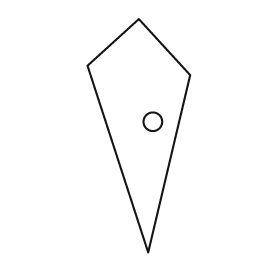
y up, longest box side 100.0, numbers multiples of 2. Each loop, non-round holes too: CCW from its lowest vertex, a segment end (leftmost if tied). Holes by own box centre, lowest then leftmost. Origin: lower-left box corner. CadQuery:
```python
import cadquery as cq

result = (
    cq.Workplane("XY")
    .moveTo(26.0, 0.0)
    .lineTo(44.0, 76.0)
    .lineTo(22.0, 100.0)
    .lineTo(0.0, 80.0)
    .close()
    .moveTo(28.0, 56.0)
    .circle(4.0)
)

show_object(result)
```